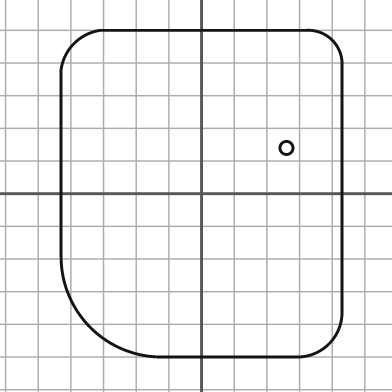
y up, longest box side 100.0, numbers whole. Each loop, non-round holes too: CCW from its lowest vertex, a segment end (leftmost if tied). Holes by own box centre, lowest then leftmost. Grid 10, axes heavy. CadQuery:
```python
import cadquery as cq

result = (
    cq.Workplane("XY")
    .moveTo(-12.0, -50.0)
    .lineTo(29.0, -50.0)
    .threePointArc((39.0, -46.0), (43.0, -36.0))
    .lineTo(43.0, 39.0)
    .threePointArc((40.0, 47.0), (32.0, 50.0))
    .lineTo(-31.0, 50.0)
    .threePointArc((-39.0, 46.0), (-43.0, 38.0))
    .lineTo(-43.0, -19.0)
    .threePointArc((-34.0, -41.0), (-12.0, -50.0))
    .close()
    .moveTo(26.0, 14.0)
    .circle(2.0)
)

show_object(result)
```